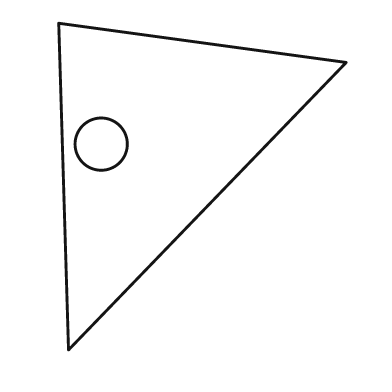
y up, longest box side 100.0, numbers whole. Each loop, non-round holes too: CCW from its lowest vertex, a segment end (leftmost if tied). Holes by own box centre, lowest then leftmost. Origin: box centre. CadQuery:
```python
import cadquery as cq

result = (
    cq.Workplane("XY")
    .moveTo(-41.0, -50.0)
    .lineTo(44.0, 38.0)
    .lineTo(-44.0, 50.0)
    .close()
    .moveTo(-31.0, 13.0)
    .circle(8.0)
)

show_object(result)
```